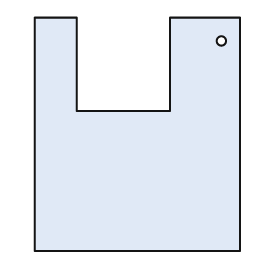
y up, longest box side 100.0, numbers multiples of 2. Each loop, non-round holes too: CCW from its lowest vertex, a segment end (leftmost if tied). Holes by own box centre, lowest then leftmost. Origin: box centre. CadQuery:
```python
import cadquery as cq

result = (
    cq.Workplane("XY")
    .moveTo(-44.0, -50.0)
    .lineTo(44.0, -50.0)
    .lineTo(44.0, 50.0)
    .lineTo(14.0, 50.0)
    .lineTo(14.0, 10.0)
    .lineTo(-26.0, 10.0)
    .lineTo(-26.0, 50.0)
    .lineTo(-44.0, 50.0)
    .close()
    .moveTo(36.0, 40.0)
    .circle(2.0)
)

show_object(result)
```